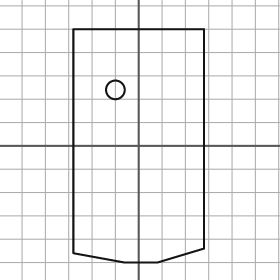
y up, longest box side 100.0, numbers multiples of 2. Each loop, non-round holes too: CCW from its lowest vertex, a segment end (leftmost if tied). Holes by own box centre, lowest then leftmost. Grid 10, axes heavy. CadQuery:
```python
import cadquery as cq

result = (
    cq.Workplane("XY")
    .moveTo(-6.0, -50.0)
    .lineTo(8.0, -50.0)
    .lineTo(28.0, -44.0)
    .lineTo(28.0, 50.0)
    .lineTo(-28.0, 50.0)
    .lineTo(-28.0, -46.0)
    .close()
    .moveTo(-10.0, 24.0)
    .circle(4.0)
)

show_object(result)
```